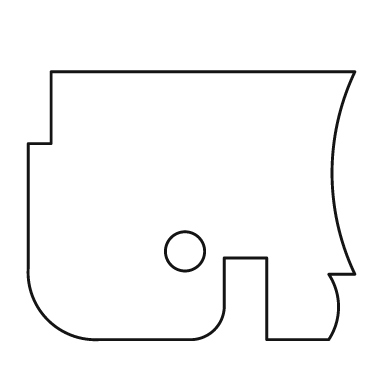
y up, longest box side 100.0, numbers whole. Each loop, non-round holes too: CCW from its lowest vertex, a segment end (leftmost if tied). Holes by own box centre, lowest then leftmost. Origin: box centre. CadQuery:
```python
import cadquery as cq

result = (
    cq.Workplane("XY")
    .moveTo(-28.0, -41.0)
    .lineTo(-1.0, -41.0)
    .threePointArc((7.0, -38.0), (10.0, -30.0))
    .lineTo(10.0, -16.0)
    .lineTo(23.0, -16.0)
    .lineTo(23.0, -41.0)
    .lineTo(42.0, -41.0)
    .threePointArc((45.0, -31.0), (42.0, -21.0))
    .lineTo(50.0, -21.0)
    .threePointArc((43.0, 10.0), (50.0, 41.0))
    .lineTo(-43.0, 41.0)
    .lineTo(-43.0, 19.0)
    .lineTo(-50.0, 19.0)
    .lineTo(-50.0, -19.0)
    .threePointArc((-44.0, -35.0), (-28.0, -41.0))
    .close()
    .moveTo(-2.0, -14.0)
    .circle(6.0)
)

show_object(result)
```